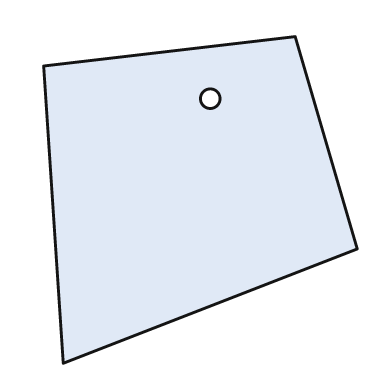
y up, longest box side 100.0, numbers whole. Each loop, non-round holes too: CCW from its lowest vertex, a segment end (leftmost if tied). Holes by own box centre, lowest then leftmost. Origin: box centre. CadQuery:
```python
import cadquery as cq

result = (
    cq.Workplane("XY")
    .moveTo(-42.0, -50.0)
    .lineTo(48.0, -15.0)
    .lineTo(29.0, 50.0)
    .lineTo(-48.0, 41.0)
    .close()
    .moveTo(3.0, 31.0)
    .circle(3.0)
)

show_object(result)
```